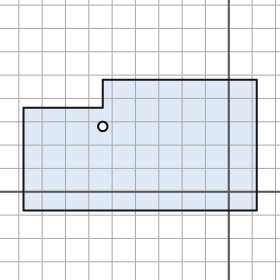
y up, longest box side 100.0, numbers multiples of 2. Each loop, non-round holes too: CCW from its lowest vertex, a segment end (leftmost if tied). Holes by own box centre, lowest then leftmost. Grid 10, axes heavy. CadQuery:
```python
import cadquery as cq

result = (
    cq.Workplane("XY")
    .moveTo(-88.0, -8.0)
    .lineTo(12.0, -8.0)
    .lineTo(12.0, 48.0)
    .lineTo(-54.0, 48.0)
    .lineTo(-54.0, 36.0)
    .lineTo(-88.0, 36.0)
    .close()
    .moveTo(-54.0, 28.0)
    .circle(2.0)
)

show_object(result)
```